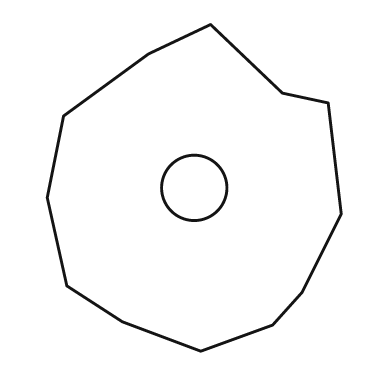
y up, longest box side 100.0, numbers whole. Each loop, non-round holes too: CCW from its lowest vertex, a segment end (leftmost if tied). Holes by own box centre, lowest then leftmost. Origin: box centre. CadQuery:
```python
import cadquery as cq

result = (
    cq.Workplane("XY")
    .moveTo(2.0, -50.0)
    .lineTo(24.0, -42.0)
    .lineTo(33.0, -32.0)
    .lineTo(45.0, -8.0)
    .lineTo(41.0, 26.0)
    .lineTo(27.0, 29.0)
    .lineTo(5.0, 50.0)
    .lineTo(-14.0, 41.0)
    .lineTo(-40.0, 22.0)
    .lineTo(-45.0, -3.0)
    .lineTo(-39.0, -30.0)
    .lineTo(-22.0, -41.0)
    .close()
    .moveTo(0.0, 0.0)
    .circle(10.0)
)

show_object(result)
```